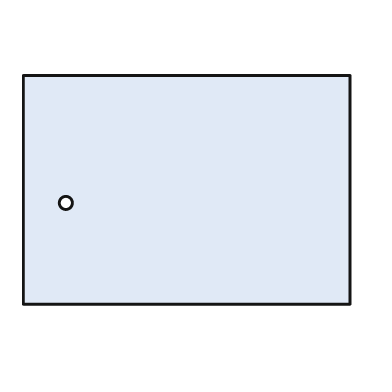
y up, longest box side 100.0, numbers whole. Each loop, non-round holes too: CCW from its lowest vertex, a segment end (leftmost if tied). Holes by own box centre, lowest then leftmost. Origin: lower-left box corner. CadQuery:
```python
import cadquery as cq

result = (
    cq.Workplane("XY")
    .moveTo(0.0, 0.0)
    .lineTo(100.0, 0.0)
    .lineTo(100.0, 70.0)
    .lineTo(0.0, 70.0)
    .close()
    .moveTo(13.0, 31.0)
    .circle(2.0)
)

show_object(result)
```